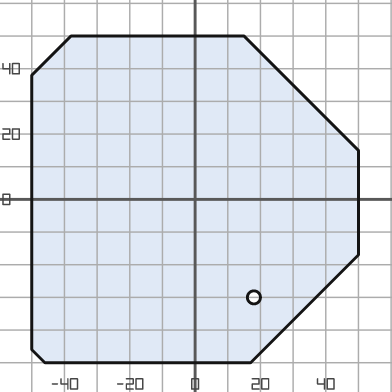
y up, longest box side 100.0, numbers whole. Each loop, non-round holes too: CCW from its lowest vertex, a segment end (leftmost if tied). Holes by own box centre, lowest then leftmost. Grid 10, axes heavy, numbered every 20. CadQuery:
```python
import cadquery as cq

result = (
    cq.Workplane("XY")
    .moveTo(-46.0, -50.0)
    .lineTo(17.0, -50.0)
    .lineTo(50.0, -17.0)
    .lineTo(50.0, 15.0)
    .lineTo(15.0, 50.0)
    .lineTo(-38.0, 50.0)
    .lineTo(-50.0, 38.0)
    .lineTo(-50.0, -46.0)
    .close()
    .moveTo(18.0, -30.0)
    .circle(2.0)
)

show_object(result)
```